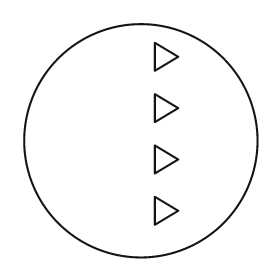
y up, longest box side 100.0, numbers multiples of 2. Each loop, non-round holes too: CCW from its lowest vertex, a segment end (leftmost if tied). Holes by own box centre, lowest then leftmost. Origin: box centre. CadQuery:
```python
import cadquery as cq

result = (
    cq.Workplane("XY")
    .moveTo(0.0, 0.0)
    .circle(50.0)
    .moveTo(6.0, -36.0)
    .lineTo(16.0, -30.0)
    .lineTo(6.0, -24.0)
    .close()
    .moveTo(6.0, -14.0)
    .lineTo(16.0, -8.0)
    .lineTo(6.0, -2.0)
    .close()
    .moveTo(6.0, 8.0)
    .lineTo(16.0, 14.0)
    .lineTo(6.0, 20.0)
    .close()
    .moveTo(6.0, 30.0)
    .lineTo(16.0, 36.0)
    .lineTo(6.0, 42.0)
    .close()
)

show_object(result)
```